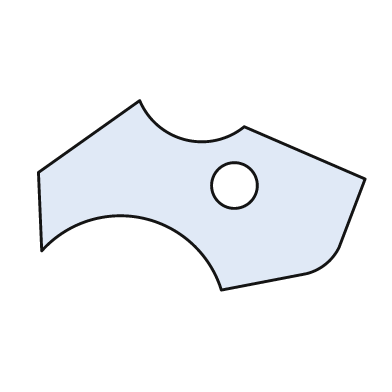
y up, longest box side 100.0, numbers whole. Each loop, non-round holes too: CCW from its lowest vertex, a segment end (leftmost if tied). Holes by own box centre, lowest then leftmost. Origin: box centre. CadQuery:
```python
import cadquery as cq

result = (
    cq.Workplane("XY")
    .moveTo(6.0, -29.0)
    .lineTo(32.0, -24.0)
    .threePointArc((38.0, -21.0), (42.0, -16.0))
    .lineTo(50.0, 5.0)
    .lineTo(13.0, 21.0)
    .threePointArc((-5.0, 17.0), (-19.0, 29.0))
    .lineTo(-50.0, 7.0)
    .lineTo(-49.0, -17.0)
    .threePointArc((-18.0, -7.0), (6.0, -29.0))
    .close()
    .moveTo(10.0, 3.0)
    .circle(7.0)
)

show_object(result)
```